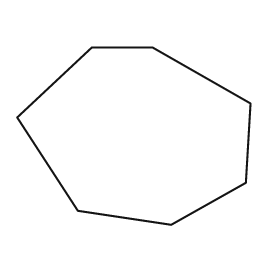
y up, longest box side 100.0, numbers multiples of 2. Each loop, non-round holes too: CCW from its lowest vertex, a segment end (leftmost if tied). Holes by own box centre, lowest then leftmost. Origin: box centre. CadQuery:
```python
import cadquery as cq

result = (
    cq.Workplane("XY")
    .moveTo(16.0, -38.0)
    .lineTo(48.0, -20.0)
    .lineTo(50.0, 14.0)
    .lineTo(8.0, 38.0)
    .lineTo(-18.0, 38.0)
    .lineTo(-50.0, 8.0)
    .lineTo(-24.0, -32.0)
    .close()
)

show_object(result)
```